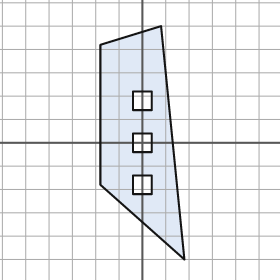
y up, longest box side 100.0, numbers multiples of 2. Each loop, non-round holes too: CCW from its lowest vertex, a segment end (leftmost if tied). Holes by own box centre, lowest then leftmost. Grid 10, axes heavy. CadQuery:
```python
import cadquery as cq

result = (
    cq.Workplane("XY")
    .moveTo(18.0, -50.0)
    .lineTo(8.0, 50.0)
    .lineTo(-18.0, 42.0)
    .lineTo(-18.0, -18.0)
    .close()
    .moveTo(-4.0, -22.0)
    .lineTo(4.0, -22.0)
    .lineTo(4.0, -14.0)
    .lineTo(-4.0, -14.0)
    .close()
    .moveTo(-4.0, -4.0)
    .lineTo(4.0, -4.0)
    .lineTo(4.0, 4.0)
    .lineTo(-4.0, 4.0)
    .close()
    .moveTo(-4.0, 14.0)
    .lineTo(4.0, 14.0)
    .lineTo(4.0, 22.0)
    .lineTo(-4.0, 22.0)
    .close()
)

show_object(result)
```